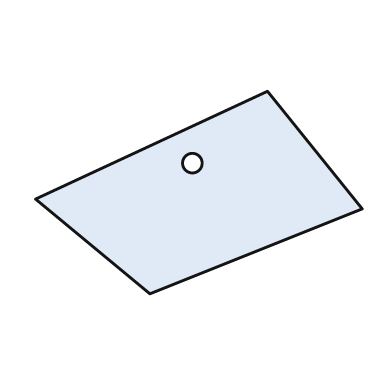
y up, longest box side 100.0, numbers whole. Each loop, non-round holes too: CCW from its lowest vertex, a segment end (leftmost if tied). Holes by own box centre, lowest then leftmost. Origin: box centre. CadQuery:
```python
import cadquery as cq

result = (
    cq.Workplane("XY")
    .moveTo(-15.0, -31.0)
    .lineTo(50.0, -5.0)
    .lineTo(21.0, 31.0)
    .lineTo(-50.0, -2.0)
    .close()
    .moveTo(-2.0, 9.0)
    .circle(3.0)
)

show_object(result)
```